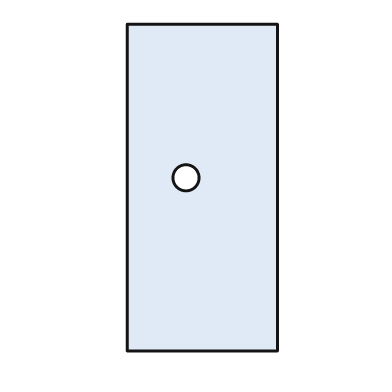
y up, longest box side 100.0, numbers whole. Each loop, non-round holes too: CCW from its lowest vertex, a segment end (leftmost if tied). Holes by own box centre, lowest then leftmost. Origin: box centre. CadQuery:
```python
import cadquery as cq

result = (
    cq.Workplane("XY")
    .moveTo(-23.0, -50.0)
    .lineTo(23.0, -50.0)
    .lineTo(23.0, 50.0)
    .lineTo(-23.0, 50.0)
    .close()
    .moveTo(-5.0, 3.0)
    .circle(4.0)
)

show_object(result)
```